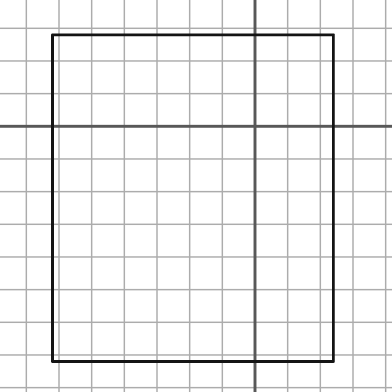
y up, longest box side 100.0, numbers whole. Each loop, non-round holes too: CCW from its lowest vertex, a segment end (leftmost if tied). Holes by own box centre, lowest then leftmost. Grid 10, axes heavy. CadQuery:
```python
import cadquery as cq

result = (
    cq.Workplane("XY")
    .moveTo(-62.0, -72.0)
    .lineTo(24.0, -72.0)
    .lineTo(24.0, 28.0)
    .lineTo(-62.0, 28.0)
    .close()
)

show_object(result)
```